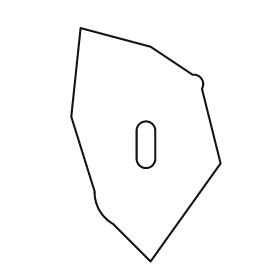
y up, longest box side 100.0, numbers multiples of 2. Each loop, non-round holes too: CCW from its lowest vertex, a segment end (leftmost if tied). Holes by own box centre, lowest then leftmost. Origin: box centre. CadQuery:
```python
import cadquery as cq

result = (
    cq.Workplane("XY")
    .moveTo(2.0, -50.0)
    .lineTo(32.0, -8.0)
    .lineTo(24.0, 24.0)
    .threePointArc((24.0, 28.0), (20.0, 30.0))
    .lineTo(2.0, 42.0)
    .lineTo(-28.0, 50.0)
    .lineTo(-32.0, 12.0)
    .lineTo(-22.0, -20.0)
    .threePointArc((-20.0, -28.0), (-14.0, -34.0))
    .close()
    .moveTo(-4.0, -6.0)
    .threePointArc((0.0, -10.0), (4.0, -6.0))
    .lineTo(4.0, 6.0)
    .threePointArc((0.0, 10.0), (-4.0, 6.0))
    .close()
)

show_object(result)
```